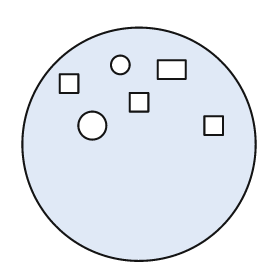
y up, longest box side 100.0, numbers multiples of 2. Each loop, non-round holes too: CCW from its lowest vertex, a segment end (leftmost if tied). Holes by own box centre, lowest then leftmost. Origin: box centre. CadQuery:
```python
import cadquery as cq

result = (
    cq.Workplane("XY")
    .moveTo(0.0, 0.0)
    .circle(50.0)
    .moveTo(-20.0, 8.0)
    .circle(6.0)
    .moveTo(28.0, 4.0)
    .lineTo(36.0, 4.0)
    .lineTo(36.0, 12.0)
    .lineTo(28.0, 12.0)
    .close()
    .moveTo(-4.0, 14.0)
    .lineTo(4.0, 14.0)
    .lineTo(4.0, 22.0)
    .lineTo(-4.0, 22.0)
    .close()
    .moveTo(-34.0, 22.0)
    .lineTo(-26.0, 22.0)
    .lineTo(-26.0, 30.0)
    .lineTo(-34.0, 30.0)
    .close()
    .moveTo(8.0, 28.0)
    .lineTo(20.0, 28.0)
    .lineTo(20.0, 36.0)
    .lineTo(8.0, 36.0)
    .close()
    .moveTo(-8.0, 34.0)
    .circle(4.0)
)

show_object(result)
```